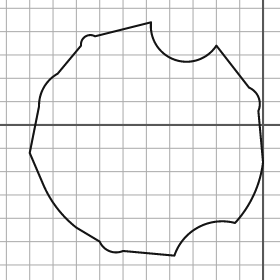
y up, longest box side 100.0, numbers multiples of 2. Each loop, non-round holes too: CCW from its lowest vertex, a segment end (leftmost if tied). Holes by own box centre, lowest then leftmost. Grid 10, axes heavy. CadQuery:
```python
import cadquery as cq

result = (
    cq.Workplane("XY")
    .moveTo(-38.0, -56.0)
    .threePointArc((-28.0, -44.0), (-12.0, -42.0))
    .threePointArc((-4.0, -30.0), (0.0, -16.0))
    .lineTo(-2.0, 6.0)
    .threePointArc((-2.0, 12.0), (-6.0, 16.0))
    .lineTo(-20.0, 34.0)
    .threePointArc((-38.0, 28.0), (-48.0, 44.0))
    .lineTo(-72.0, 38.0)
    .threePointArc((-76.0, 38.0), (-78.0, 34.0))
    .lineTo(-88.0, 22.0)
    .threePointArc((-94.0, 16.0), (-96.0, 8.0))
    .lineTo(-100.0, -12.0)
    .lineTo(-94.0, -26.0)
    .threePointArc((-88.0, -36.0), (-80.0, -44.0))
    .lineTo(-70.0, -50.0)
    .threePointArc((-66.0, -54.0), (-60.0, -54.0))
    .close()
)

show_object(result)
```